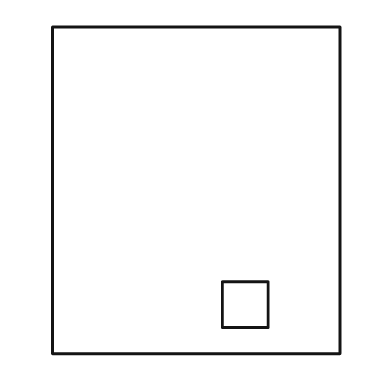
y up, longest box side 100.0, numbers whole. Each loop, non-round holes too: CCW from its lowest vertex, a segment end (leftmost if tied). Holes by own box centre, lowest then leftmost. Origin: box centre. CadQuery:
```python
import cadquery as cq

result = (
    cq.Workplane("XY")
    .moveTo(-44.0, -50.0)
    .lineTo(44.0, -50.0)
    .lineTo(44.0, 50.0)
    .lineTo(-44.0, 50.0)
    .close()
    .moveTo(8.0, -42.0)
    .lineTo(22.0, -42.0)
    .lineTo(22.0, -28.0)
    .lineTo(8.0, -28.0)
    .close()
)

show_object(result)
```